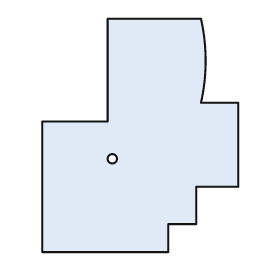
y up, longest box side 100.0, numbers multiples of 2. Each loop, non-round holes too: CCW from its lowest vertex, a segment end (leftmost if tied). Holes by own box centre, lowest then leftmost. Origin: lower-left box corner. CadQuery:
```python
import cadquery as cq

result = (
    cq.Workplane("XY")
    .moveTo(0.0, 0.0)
    .lineTo(54.0, 0.0)
    .lineTo(54.0, 12.0)
    .lineTo(66.0, 12.0)
    .lineTo(66.0, 28.0)
    .lineTo(84.0, 28.0)
    .lineTo(84.0, 64.0)
    .lineTo(68.0, 64.0)
    .threePointArc((70.0, 82.0), (68.0, 100.0))
    .lineTo(28.0, 100.0)
    .lineTo(28.0, 56.0)
    .lineTo(0.0, 56.0)
    .close()
    .moveTo(30.0, 40.0)
    .circle(2.0)
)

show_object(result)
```